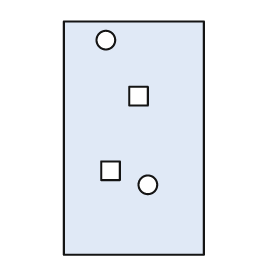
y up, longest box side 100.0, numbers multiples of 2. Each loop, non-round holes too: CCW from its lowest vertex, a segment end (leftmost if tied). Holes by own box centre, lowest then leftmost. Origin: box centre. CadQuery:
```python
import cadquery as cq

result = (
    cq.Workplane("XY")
    .moveTo(-30.0, -50.0)
    .lineTo(30.0, -50.0)
    .lineTo(30.0, 50.0)
    .lineTo(-30.0, 50.0)
    .close()
    .moveTo(6.0, -20.0)
    .circle(4.0)
    .moveTo(-14.0, -18.0)
    .lineTo(-6.0, -18.0)
    .lineTo(-6.0, -10.0)
    .lineTo(-14.0, -10.0)
    .close()
    .moveTo(-2.0, 14.0)
    .lineTo(6.0, 14.0)
    .lineTo(6.0, 22.0)
    .lineTo(-2.0, 22.0)
    .close()
    .moveTo(-12.0, 42.0)
    .circle(4.0)
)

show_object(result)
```